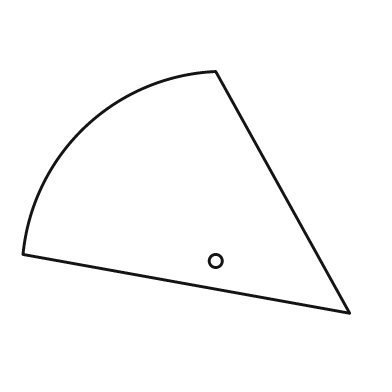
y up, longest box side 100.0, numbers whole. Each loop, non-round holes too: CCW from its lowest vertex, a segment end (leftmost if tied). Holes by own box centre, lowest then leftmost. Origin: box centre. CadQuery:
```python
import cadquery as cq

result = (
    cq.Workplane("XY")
    .moveTo(50.0, -37.0)
    .lineTo(9.0, 37.0)
    .threePointArc((-31.0, 20.0), (-50.0, -19.0))
    .close()
    .moveTo(9.0, -21.0)
    .circle(2.0)
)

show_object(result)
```